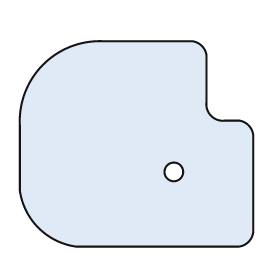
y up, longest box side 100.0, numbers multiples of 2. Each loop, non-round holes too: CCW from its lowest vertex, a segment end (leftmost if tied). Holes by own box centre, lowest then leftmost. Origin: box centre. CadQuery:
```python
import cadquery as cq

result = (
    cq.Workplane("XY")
    .moveTo(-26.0, -44.0)
    .lineTo(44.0, -44.0)
    .threePointArc((48.0, -42.0), (50.0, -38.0))
    .lineTo(50.0, 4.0)
    .threePointArc((48.0, 8.0), (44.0, 10.0))
    .lineTo(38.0, 10.0)
    .threePointArc((32.0, 12.0), (30.0, 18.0))
    .lineTo(30.0, 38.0)
    .threePointArc((28.0, 42.0), (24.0, 44.0))
    .lineTo(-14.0, 44.0)
    .threePointArc((-40.0, 34.0), (-50.0, 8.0))
    .lineTo(-50.0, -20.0)
    .threePointArc((-42.0, -36.0), (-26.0, -44.0))
    .close()
    .moveTo(16.0, -12.0)
    .circle(4.0)
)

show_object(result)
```